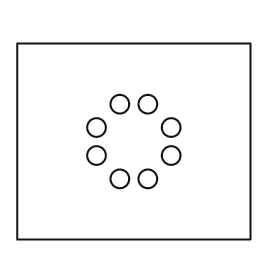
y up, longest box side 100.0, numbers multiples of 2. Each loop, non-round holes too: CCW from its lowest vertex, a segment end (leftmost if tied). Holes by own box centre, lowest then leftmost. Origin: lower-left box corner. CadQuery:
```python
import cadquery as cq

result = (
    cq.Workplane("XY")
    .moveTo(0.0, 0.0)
    .lineTo(100.0, 0.0)
    .lineTo(100.0, 84.0)
    .lineTo(0.0, 84.0)
    .close()
    .moveTo(44.0, 26.0)
    .circle(4.0)
    .moveTo(56.0, 26.0)
    .circle(4.0)
    .moveTo(34.0, 36.0)
    .circle(4.0)
    .moveTo(66.0, 36.0)
    .circle(4.0)
    .moveTo(34.0, 48.0)
    .circle(4.0)
    .moveTo(66.0, 48.0)
    .circle(4.0)
    .moveTo(44.0, 58.0)
    .circle(4.0)
    .moveTo(56.0, 58.0)
    .circle(4.0)
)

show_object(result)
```